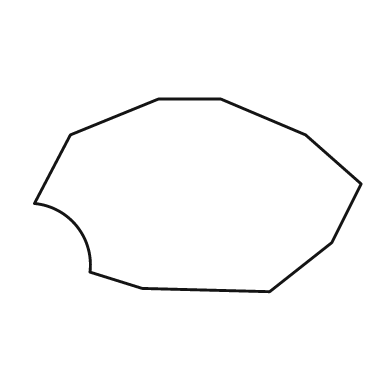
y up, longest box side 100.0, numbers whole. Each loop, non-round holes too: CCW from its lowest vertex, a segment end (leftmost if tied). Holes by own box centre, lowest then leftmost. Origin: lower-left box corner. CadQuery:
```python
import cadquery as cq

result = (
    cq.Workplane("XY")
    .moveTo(72.0, 0.0)
    .lineTo(91.0, 15.0)
    .lineTo(100.0, 33.0)
    .lineTo(83.0, 48.0)
    .lineTo(57.0, 59.0)
    .lineTo(38.0, 59.0)
    .lineTo(11.0, 48.0)
    .lineTo(0.0, 27.0)
    .threePointArc((13.0, 20.0), (17.0, 6.0))
    .lineTo(33.0, 1.0)
    .close()
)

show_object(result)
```